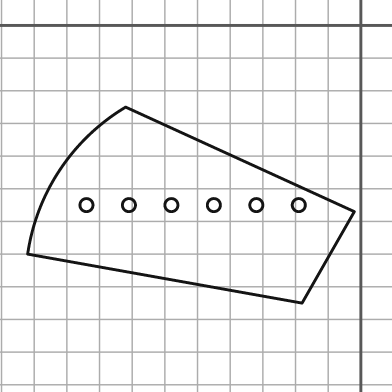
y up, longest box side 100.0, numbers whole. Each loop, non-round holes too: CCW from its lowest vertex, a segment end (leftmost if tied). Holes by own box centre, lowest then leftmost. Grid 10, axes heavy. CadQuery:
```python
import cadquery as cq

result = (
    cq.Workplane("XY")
    .moveTo(-18.0, -85.0)
    .lineTo(-2.0, -57.0)
    .lineTo(-72.0, -25.0)
    .threePointArc((-92.0, -44.0), (-102.0, -70.0))
    .close()
    .moveTo(-84.0, -55.0)
    .circle(2.0)
    .moveTo(-71.0, -55.0)
    .circle(2.0)
    .moveTo(-58.0, -55.0)
    .circle(2.0)
    .moveTo(-45.0, -55.0)
    .circle(2.0)
    .moveTo(-32.0, -55.0)
    .circle(2.0)
    .moveTo(-19.0, -55.0)
    .circle(2.0)
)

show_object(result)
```